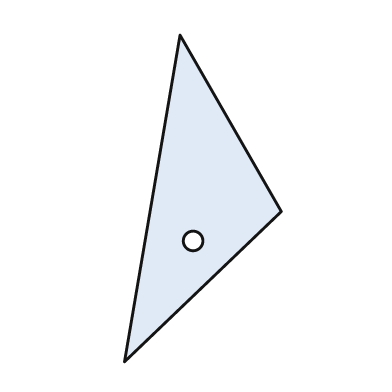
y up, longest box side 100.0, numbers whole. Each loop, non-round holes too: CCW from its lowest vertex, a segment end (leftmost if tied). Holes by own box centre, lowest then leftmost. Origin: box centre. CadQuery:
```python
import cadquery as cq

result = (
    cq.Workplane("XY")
    .moveTo(-24.0, -50.0)
    .lineTo(24.0, -4.0)
    .lineTo(-7.0, 50.0)
    .close()
    .moveTo(-3.0, -13.0)
    .circle(3.0)
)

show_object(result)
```